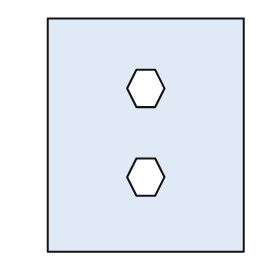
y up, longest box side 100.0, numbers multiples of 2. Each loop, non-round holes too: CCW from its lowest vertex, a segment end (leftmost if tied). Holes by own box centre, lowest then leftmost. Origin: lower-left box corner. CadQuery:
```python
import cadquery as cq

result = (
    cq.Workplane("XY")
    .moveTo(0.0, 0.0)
    .lineTo(84.0, 0.0)
    .lineTo(84.0, 100.0)
    .lineTo(0.0, 100.0)
    .close()
    .moveTo(38.0, 24.0)
    .lineTo(46.0, 24.0)
    .lineTo(50.0, 32.0)
    .lineTo(46.0, 40.0)
    .lineTo(38.0, 40.0)
    .lineTo(34.0, 32.0)
    .close()
    .moveTo(38.0, 62.0)
    .lineTo(46.0, 62.0)
    .lineTo(50.0, 70.0)
    .lineTo(46.0, 78.0)
    .lineTo(38.0, 78.0)
    .lineTo(34.0, 70.0)
    .close()
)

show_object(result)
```